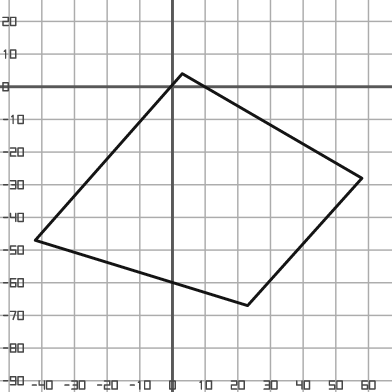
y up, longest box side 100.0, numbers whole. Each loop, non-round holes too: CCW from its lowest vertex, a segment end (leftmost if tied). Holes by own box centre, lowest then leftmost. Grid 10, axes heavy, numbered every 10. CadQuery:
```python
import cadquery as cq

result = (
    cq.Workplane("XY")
    .moveTo(23.0, -67.0)
    .lineTo(58.0, -28.0)
    .lineTo(3.0, 4.0)
    .lineTo(-42.0, -47.0)
    .close()
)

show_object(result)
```